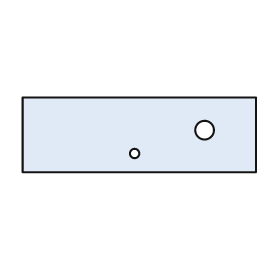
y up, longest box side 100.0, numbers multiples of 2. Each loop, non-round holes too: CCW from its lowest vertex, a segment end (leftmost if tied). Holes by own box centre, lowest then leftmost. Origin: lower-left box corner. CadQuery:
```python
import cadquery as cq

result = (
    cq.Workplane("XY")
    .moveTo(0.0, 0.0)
    .lineTo(100.0, 0.0)
    .lineTo(100.0, 32.0)
    .lineTo(0.0, 32.0)
    .close()
    .moveTo(48.0, 8.0)
    .circle(2.0)
    .moveTo(78.0, 18.0)
    .circle(4.0)
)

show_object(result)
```